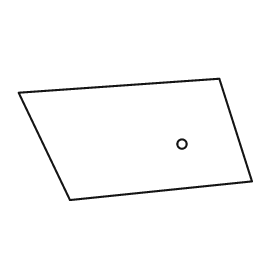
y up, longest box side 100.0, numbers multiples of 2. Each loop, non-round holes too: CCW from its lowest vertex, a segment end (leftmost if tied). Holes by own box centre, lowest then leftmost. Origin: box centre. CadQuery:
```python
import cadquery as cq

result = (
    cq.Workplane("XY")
    .moveTo(-28.0, -26.0)
    .lineTo(50.0, -18.0)
    .lineTo(36.0, 26.0)
    .lineTo(-50.0, 20.0)
    .close()
    .moveTo(20.0, -2.0)
    .circle(2.0)
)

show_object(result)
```